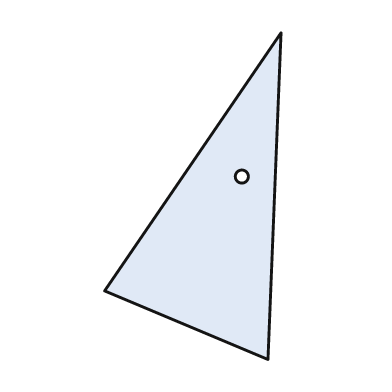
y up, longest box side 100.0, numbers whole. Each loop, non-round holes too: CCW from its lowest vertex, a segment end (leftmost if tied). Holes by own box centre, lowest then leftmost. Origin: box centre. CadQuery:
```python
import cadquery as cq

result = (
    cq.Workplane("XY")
    .moveTo(23.0, -50.0)
    .lineTo(27.0, 50.0)
    .lineTo(-27.0, -29.0)
    .close()
    .moveTo(15.0, 6.0)
    .circle(2.0)
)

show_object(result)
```